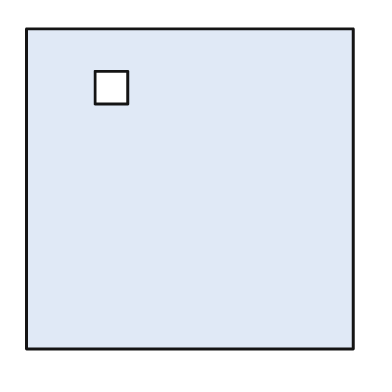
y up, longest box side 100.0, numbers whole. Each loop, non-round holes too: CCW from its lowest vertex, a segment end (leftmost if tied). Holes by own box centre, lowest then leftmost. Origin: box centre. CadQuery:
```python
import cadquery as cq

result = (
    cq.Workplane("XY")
    .moveTo(-50.0, -49.0)
    .lineTo(50.0, -49.0)
    .lineTo(50.0, 49.0)
    .lineTo(-50.0, 49.0)
    .close()
    .moveTo(-29.0, 26.0)
    .lineTo(-19.0, 26.0)
    .lineTo(-19.0, 36.0)
    .lineTo(-29.0, 36.0)
    .close()
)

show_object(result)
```